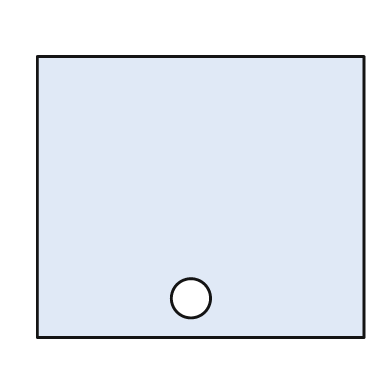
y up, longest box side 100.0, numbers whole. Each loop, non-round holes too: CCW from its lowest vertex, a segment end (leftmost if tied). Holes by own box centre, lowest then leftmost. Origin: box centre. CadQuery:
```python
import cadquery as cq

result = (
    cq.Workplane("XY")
    .moveTo(-50.0, -43.0)
    .lineTo(50.0, -43.0)
    .lineTo(50.0, 43.0)
    .lineTo(-50.0, 43.0)
    .close()
    .moveTo(-3.0, -31.0)
    .circle(6.0)
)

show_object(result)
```